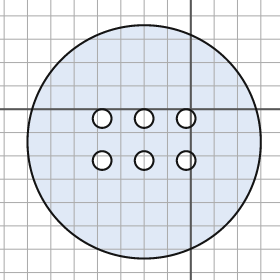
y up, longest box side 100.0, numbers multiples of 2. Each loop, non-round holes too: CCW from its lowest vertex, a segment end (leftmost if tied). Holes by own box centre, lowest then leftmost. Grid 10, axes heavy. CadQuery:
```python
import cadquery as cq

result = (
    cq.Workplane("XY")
    .moveTo(-20.0, -14.0)
    .circle(50.0)
    .moveTo(-38.0, -22.0)
    .circle(4.0)
    .moveTo(-20.0, -22.0)
    .circle(4.0)
    .moveTo(-2.0, -22.0)
    .circle(4.0)
    .moveTo(-38.0, -4.0)
    .circle(4.0)
    .moveTo(-20.0, -4.0)
    .circle(4.0)
    .moveTo(-2.0, -4.0)
    .circle(4.0)
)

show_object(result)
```